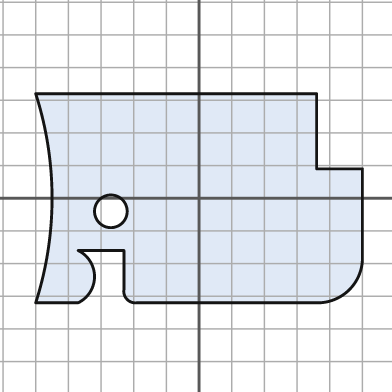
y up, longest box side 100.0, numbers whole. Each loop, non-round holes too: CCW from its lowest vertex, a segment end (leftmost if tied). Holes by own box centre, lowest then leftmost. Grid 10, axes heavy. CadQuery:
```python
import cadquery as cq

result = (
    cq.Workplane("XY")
    .moveTo(-50.0, -32.0)
    .lineTo(-37.0, -32.0)
    .threePointArc((-32.0, -24.0), (-37.0, -16.0))
    .lineTo(-23.0, -16.0)
    .lineTo(-23.0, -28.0)
    .threePointArc((-22.0, -31.0), (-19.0, -32.0))
    .lineTo(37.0, -32.0)
    .threePointArc((46.0, -28.0), (50.0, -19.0))
    .lineTo(50.0, 9.0)
    .lineTo(36.0, 9.0)
    .lineTo(36.0, 32.0)
    .lineTo(-50.0, 32.0)
    .threePointArc((-45.0, 0.0), (-50.0, -32.0))
    .close()
    .moveTo(-27.0, -4.0)
    .circle(5.0)
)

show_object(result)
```